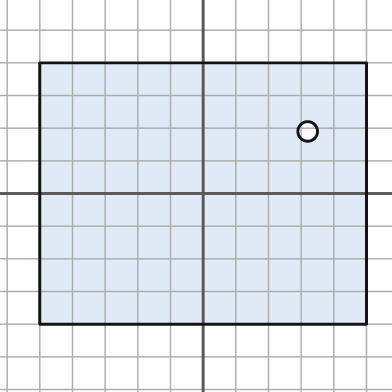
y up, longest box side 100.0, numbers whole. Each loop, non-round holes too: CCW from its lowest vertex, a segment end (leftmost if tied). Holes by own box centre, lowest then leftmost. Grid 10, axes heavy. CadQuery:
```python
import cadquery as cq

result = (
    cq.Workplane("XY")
    .moveTo(-50.0, -40.0)
    .lineTo(50.0, -40.0)
    .lineTo(50.0, 40.0)
    .lineTo(-50.0, 40.0)
    .close()
    .moveTo(32.0, 19.0)
    .circle(3.0)
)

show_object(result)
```